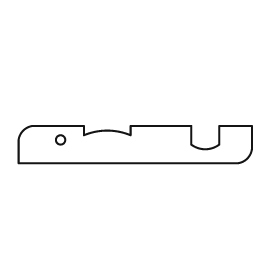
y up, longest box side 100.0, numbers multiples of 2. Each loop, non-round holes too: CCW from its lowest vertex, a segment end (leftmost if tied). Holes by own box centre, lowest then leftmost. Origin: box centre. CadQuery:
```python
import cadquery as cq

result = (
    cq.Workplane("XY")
    .moveTo(-50.0, -8.0)
    .lineTo(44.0, -8.0)
    .threePointArc((48.0, -6.0), (50.0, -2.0))
    .lineTo(50.0, 8.0)
    .lineTo(36.0, 8.0)
    .lineTo(36.0, 0.0)
    .threePointArc((30.0, -2.0), (24.0, 0.0))
    .lineTo(24.0, 8.0)
    .lineTo(-2.0, 8.0)
    .lineTo(-2.0, 4.0)
    .threePointArc((-12.0, 6.0), (-22.0, 4.0))
    .lineTo(-22.0, 8.0)
    .lineTo(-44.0, 8.0)
    .threePointArc((-48.0, 6.0), (-50.0, 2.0))
    .close()
    .moveTo(-32.0, 2.0)
    .circle(2.0)
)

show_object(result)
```